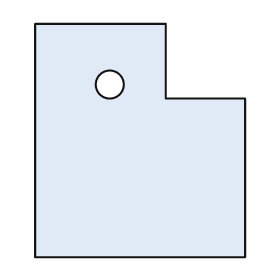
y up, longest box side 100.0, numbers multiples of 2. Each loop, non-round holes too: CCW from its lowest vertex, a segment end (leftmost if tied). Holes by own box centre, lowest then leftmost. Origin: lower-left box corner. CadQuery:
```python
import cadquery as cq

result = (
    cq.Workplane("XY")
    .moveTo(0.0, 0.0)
    .lineTo(90.0, 0.0)
    .lineTo(90.0, 68.0)
    .lineTo(56.0, 68.0)
    .lineTo(56.0, 100.0)
    .lineTo(0.0, 100.0)
    .close()
    .moveTo(32.0, 74.0)
    .circle(6.0)
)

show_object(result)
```